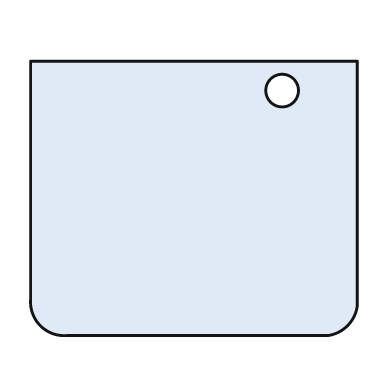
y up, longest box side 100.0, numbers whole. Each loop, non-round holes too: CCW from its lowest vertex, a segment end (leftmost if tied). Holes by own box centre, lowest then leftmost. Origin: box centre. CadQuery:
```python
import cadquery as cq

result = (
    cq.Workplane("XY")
    .moveTo(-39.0, -42.0)
    .lineTo(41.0, -42.0)
    .threePointArc((47.0, -39.0), (50.0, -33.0))
    .lineTo(50.0, 42.0)
    .lineTo(-50.0, 42.0)
    .lineTo(-50.0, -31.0)
    .threePointArc((-47.0, -39.0), (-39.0, -42.0))
    .close()
    .moveTo(27.0, 33.0)
    .circle(5.0)
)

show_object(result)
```